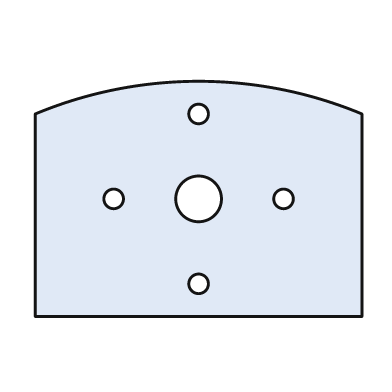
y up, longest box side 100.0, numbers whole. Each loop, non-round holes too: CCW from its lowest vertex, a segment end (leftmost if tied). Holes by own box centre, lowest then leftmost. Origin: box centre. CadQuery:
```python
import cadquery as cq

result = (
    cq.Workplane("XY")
    .moveTo(-50.0, -36.0)
    .lineTo(50.0, -36.0)
    .lineTo(50.0, 26.0)
    .threePointArc((0.0, 36.0), (-50.0, 26.0))
    .close()
    .moveTo(0.0, -26.0)
    .circle(3.0)
    .moveTo(-26.0, 0.0)
    .circle(3.0)
    .moveTo(0.0, 0.0)
    .circle(7.0)
    .moveTo(26.0, 0.0)
    .circle(3.0)
    .moveTo(0.0, 26.0)
    .circle(3.0)
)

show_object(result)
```